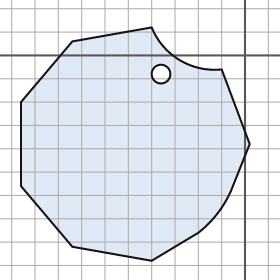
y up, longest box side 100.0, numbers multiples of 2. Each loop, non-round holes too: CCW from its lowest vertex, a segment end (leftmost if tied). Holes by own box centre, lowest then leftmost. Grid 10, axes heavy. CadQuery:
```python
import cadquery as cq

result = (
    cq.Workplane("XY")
    .moveTo(-40.0, -88.0)
    .lineTo(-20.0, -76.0)
    .threePointArc((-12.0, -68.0), (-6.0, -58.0))
    .lineTo(2.0, -38.0)
    .lineTo(-10.0, -6.0)
    .threePointArc((-28.0, -2.0), (-40.0, 12.0))
    .lineTo(-74.0, 6.0)
    .lineTo(-96.0, -20.0)
    .lineTo(-96.0, -56.0)
    .lineTo(-74.0, -82.0)
    .close()
    .moveTo(-36.0, -8.0)
    .circle(4.0)
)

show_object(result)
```